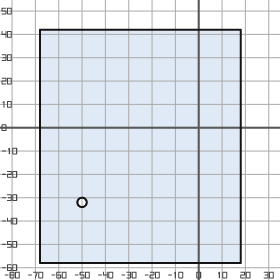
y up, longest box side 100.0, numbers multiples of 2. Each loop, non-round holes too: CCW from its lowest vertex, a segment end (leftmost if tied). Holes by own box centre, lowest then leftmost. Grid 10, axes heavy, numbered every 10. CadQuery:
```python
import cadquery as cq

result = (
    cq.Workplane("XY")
    .moveTo(-68.0, -58.0)
    .lineTo(18.0, -58.0)
    .lineTo(18.0, 42.0)
    .lineTo(-68.0, 42.0)
    .close()
    .moveTo(-50.0, -32.0)
    .circle(2.0)
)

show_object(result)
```